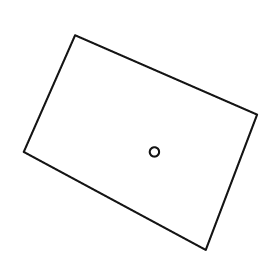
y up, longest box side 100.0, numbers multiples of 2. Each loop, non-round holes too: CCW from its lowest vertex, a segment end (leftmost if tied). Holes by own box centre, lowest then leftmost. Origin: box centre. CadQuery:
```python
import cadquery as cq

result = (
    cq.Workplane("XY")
    .moveTo(28.0, -46.0)
    .lineTo(50.0, 12.0)
    .lineTo(-28.0, 46.0)
    .lineTo(-50.0, -4.0)
    .close()
    .moveTo(6.0, -4.0)
    .circle(2.0)
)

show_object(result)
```